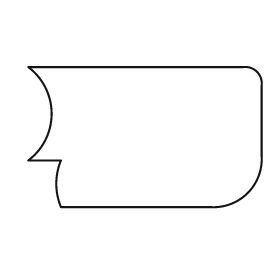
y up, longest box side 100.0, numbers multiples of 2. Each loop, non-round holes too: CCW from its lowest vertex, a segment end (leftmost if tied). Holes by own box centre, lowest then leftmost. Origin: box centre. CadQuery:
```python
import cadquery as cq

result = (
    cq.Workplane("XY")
    .moveTo(-36.0, -30.0)
    .lineTo(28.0, -30.0)
    .threePointArc((44.0, -24.0), (50.0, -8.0))
    .lineTo(50.0, 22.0)
    .threePointArc((48.0, 28.0), (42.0, 30.0))
    .lineTo(-50.0, 30.0)
    .threePointArc((-40.0, 10.0), (-50.0, -10.0))
    .lineTo(-36.0, -10.0)
    .threePointArc((-38.0, -20.0), (-36.0, -30.0))
    .close()
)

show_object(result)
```